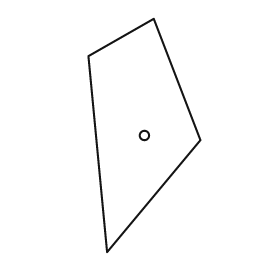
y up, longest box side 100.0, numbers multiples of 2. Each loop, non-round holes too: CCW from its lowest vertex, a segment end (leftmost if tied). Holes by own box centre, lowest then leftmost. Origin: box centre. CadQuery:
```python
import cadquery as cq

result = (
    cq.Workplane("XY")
    .moveTo(-16.0, -50.0)
    .lineTo(24.0, -2.0)
    .lineTo(4.0, 50.0)
    .lineTo(-24.0, 34.0)
    .close()
    .moveTo(0.0, 0.0)
    .circle(2.0)
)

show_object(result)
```